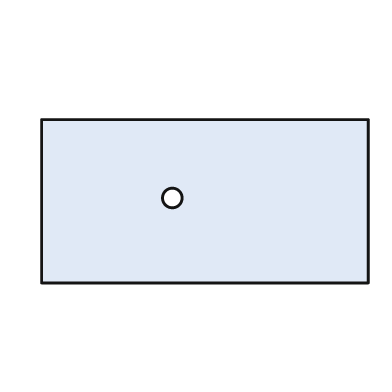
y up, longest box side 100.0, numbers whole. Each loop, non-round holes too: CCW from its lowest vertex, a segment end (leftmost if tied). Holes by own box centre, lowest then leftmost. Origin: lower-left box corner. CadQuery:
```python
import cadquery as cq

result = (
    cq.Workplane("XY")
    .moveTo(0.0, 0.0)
    .lineTo(100.0, 0.0)
    .lineTo(100.0, 50.0)
    .lineTo(0.0, 50.0)
    .close()
    .moveTo(40.0, 26.0)
    .circle(3.0)
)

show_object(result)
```